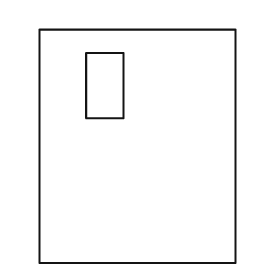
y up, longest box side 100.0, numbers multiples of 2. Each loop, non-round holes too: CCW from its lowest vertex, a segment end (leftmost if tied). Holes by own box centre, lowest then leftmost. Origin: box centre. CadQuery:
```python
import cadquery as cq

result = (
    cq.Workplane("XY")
    .moveTo(-42.0, -50.0)
    .lineTo(42.0, -50.0)
    .lineTo(42.0, 50.0)
    .lineTo(-42.0, 50.0)
    .close()
    .moveTo(-22.0, 12.0)
    .lineTo(-6.0, 12.0)
    .lineTo(-6.0, 40.0)
    .lineTo(-22.0, 40.0)
    .close()
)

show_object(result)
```